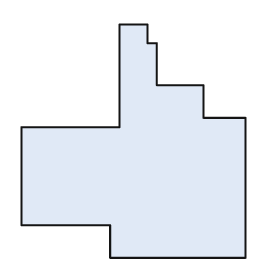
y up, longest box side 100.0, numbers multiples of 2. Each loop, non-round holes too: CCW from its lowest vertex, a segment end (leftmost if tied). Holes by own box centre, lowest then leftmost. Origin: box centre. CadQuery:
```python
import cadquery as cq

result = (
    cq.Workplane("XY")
    .moveTo(-10.0, -50.0)
    .lineTo(48.0, -50.0)
    .lineTo(48.0, 10.0)
    .lineTo(30.0, 10.0)
    .lineTo(30.0, 24.0)
    .lineTo(10.0, 24.0)
    .lineTo(10.0, 42.0)
    .lineTo(6.0, 42.0)
    .lineTo(6.0, 50.0)
    .lineTo(-6.0, 50.0)
    .lineTo(-6.0, 6.0)
    .lineTo(-48.0, 6.0)
    .lineTo(-48.0, -36.0)
    .lineTo(-10.0, -36.0)
    .close()
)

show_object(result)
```